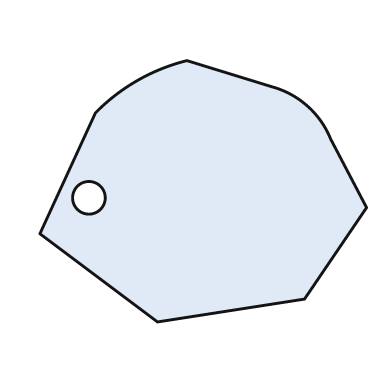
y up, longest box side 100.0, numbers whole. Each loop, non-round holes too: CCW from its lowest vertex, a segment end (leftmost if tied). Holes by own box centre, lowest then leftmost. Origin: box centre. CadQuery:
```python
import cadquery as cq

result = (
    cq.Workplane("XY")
    .moveTo(-14.0, -40.0)
    .lineTo(31.0, -33.0)
    .lineTo(50.0, -5.0)
    .lineTo(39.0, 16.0)
    .threePointArc((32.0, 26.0), (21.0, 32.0))
    .lineTo(-5.0, 40.0)
    .threePointArc((-20.0, 34.0), (-33.0, 24.0))
    .lineTo(-50.0, -13.0)
    .close()
    .moveTo(-35.0, -2.0)
    .circle(5.0)
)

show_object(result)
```